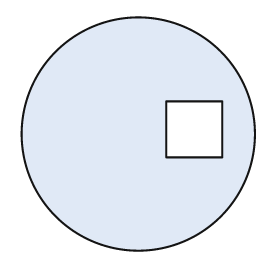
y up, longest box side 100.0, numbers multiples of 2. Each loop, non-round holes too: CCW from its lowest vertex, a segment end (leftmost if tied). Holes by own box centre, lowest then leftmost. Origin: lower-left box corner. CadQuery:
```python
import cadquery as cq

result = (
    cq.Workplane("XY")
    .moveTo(50.0, 50.0)
    .circle(50.0)
    .moveTo(62.0, 40.0)
    .lineTo(86.0, 40.0)
    .lineTo(86.0, 64.0)
    .lineTo(62.0, 64.0)
    .close()
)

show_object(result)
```